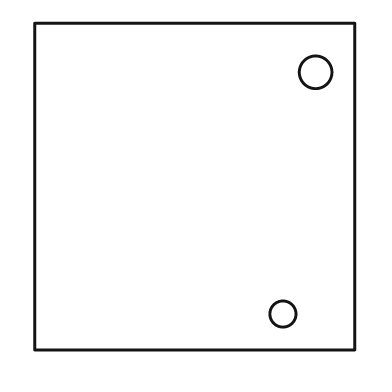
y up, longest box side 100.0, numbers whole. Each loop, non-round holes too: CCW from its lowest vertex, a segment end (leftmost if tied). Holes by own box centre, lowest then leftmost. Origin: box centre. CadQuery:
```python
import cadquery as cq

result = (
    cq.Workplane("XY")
    .moveTo(-49.0, -50.0)
    .lineTo(49.0, -50.0)
    .lineTo(49.0, 50.0)
    .lineTo(-49.0, 50.0)
    .close()
    .moveTo(27.0, -39.0)
    .circle(4.0)
    .moveTo(37.0, 35.0)
    .circle(5.0)
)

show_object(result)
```